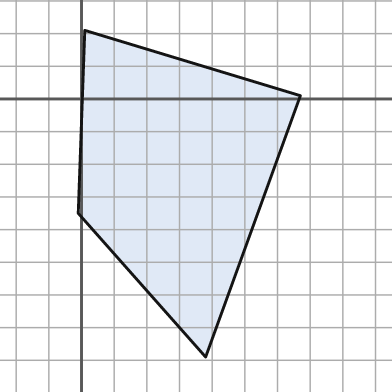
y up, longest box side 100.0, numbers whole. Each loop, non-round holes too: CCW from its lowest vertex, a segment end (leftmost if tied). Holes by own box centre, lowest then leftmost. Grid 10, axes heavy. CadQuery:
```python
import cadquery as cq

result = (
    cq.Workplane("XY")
    .moveTo(38.0, -79.0)
    .lineTo(67.0, 1.0)
    .lineTo(1.0, 21.0)
    .lineTo(-1.0, -35.0)
    .close()
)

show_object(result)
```